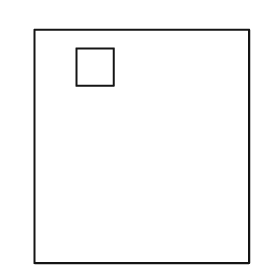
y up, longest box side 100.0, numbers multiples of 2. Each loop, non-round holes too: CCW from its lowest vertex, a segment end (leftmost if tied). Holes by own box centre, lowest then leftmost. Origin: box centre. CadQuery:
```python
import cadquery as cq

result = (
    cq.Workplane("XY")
    .moveTo(-46.0, -50.0)
    .lineTo(46.0, -50.0)
    .lineTo(46.0, 50.0)
    .lineTo(-46.0, 50.0)
    .close()
    .moveTo(-28.0, 26.0)
    .lineTo(-12.0, 26.0)
    .lineTo(-12.0, 42.0)
    .lineTo(-28.0, 42.0)
    .close()
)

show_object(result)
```